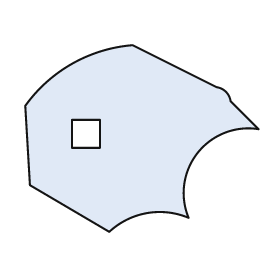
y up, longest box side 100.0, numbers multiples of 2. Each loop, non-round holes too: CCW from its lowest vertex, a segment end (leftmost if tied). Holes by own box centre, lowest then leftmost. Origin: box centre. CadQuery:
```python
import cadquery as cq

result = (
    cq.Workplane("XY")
    .moveTo(-14.0, -40.0)
    .threePointArc((2.0, -32.0), (20.0, -34.0))
    .threePointArc((24.0, -6.0), (50.0, 4.0))
    .lineTo(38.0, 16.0)
    .threePointArc((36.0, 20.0), (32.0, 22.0))
    .lineTo(-4.0, 40.0)
    .threePointArc((-30.0, 32.0), (-50.0, 14.0))
    .lineTo(-48.0, -20.0)
    .close()
    .moveTo(-30.0, -4.0)
    .lineTo(-18.0, -4.0)
    .lineTo(-18.0, 8.0)
    .lineTo(-30.0, 8.0)
    .close()
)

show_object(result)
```